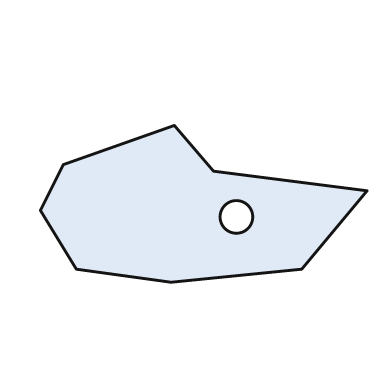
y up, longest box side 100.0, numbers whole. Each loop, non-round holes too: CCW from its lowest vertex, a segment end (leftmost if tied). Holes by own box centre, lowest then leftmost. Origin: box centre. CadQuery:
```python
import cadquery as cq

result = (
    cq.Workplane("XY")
    .moveTo(-10.0, -24.0)
    .lineTo(30.0, -20.0)
    .lineTo(50.0, 4.0)
    .lineTo(3.0, 10.0)
    .lineTo(-9.0, 24.0)
    .lineTo(-43.0, 12.0)
    .lineTo(-50.0, -2.0)
    .lineTo(-39.0, -20.0)
    .close()
    .moveTo(10.0, -4.0)
    .circle(5.0)
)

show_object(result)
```